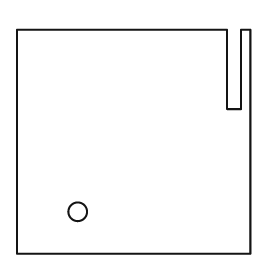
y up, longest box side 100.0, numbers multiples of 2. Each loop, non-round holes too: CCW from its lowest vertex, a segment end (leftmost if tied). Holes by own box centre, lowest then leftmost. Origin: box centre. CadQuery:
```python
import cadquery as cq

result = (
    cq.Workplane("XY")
    .moveTo(-50.0, -48.0)
    .lineTo(50.0, -48.0)
    .lineTo(50.0, 48.0)
    .lineTo(46.0, 48.0)
    .lineTo(46.0, 14.0)
    .lineTo(40.0, 14.0)
    .lineTo(40.0, 48.0)
    .lineTo(-50.0, 48.0)
    .close()
    .moveTo(-24.0, -30.0)
    .circle(4.0)
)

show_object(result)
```